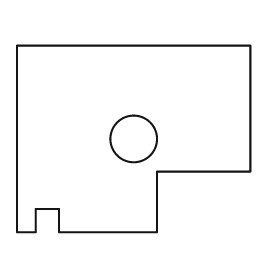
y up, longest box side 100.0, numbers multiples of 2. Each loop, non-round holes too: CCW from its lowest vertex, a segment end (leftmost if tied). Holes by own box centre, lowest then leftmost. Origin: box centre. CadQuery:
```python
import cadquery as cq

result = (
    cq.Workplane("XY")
    .moveTo(-50.0, -40.0)
    .lineTo(-42.0, -40.0)
    .lineTo(-42.0, -30.0)
    .lineTo(-32.0, -30.0)
    .lineTo(-32.0, -40.0)
    .lineTo(10.0, -40.0)
    .lineTo(10.0, -14.0)
    .lineTo(50.0, -14.0)
    .lineTo(50.0, 40.0)
    .lineTo(-50.0, 40.0)
    .close()
    .moveTo(0.0, 0.0)
    .circle(10.0)
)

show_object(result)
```